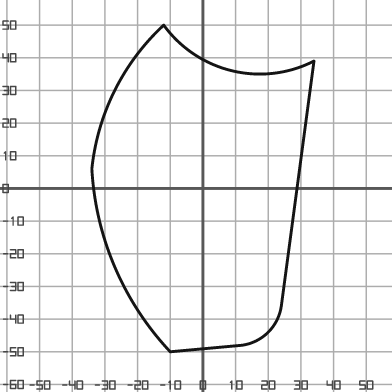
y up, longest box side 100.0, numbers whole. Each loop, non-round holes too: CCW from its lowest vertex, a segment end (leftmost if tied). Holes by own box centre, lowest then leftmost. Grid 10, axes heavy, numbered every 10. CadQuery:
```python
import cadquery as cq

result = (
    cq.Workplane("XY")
    .moveTo(-10.0, -50.0)
    .lineTo(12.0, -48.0)
    .threePointArc((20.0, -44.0), (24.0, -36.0))
    .lineTo(34.0, 39.0)
    .threePointArc((9.0, 36.0), (-12.0, 50.0))
    .threePointArc((-27.0, 30.0), (-34.0, 6.0))
    .threePointArc((-27.0, -24.0), (-10.0, -50.0))
    .close()
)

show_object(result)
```